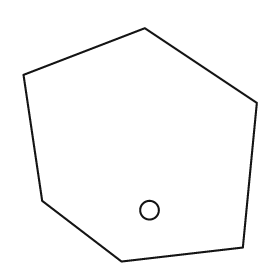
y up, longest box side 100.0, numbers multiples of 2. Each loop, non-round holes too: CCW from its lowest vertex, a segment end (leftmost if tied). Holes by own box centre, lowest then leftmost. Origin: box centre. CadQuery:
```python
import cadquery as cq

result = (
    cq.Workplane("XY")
    .moveTo(-8.0, -50.0)
    .lineTo(44.0, -44.0)
    .lineTo(50.0, 18.0)
    .lineTo(2.0, 50.0)
    .lineTo(-50.0, 30.0)
    .lineTo(-42.0, -24.0)
    .close()
    .moveTo(4.0, -28.0)
    .circle(4.0)
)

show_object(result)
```